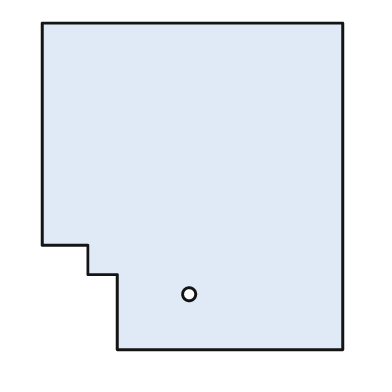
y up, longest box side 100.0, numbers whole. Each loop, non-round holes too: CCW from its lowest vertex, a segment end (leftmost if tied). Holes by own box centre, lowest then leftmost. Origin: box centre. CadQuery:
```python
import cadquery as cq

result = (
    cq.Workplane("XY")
    .moveTo(-23.0, -50.0)
    .lineTo(46.0, -50.0)
    .lineTo(46.0, 50.0)
    .lineTo(-46.0, 50.0)
    .lineTo(-46.0, -18.0)
    .lineTo(-32.0, -18.0)
    .lineTo(-32.0, -27.0)
    .lineTo(-23.0, -27.0)
    .close()
    .moveTo(-1.0, -33.0)
    .circle(2.0)
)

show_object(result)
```